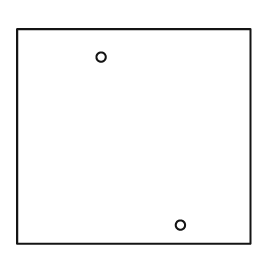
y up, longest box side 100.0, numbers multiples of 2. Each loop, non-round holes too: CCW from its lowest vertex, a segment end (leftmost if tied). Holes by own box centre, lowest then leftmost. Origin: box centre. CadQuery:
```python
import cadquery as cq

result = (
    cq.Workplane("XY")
    .moveTo(-50.0, -46.0)
    .lineTo(50.0, -46.0)
    .lineTo(50.0, 46.0)
    .lineTo(-50.0, 46.0)
    .close()
    .moveTo(20.0, -38.0)
    .circle(2.0)
    .moveTo(-14.0, 34.0)
    .circle(2.0)
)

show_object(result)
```